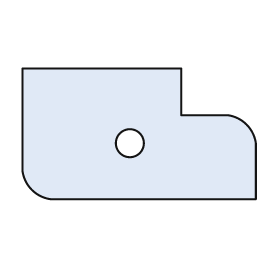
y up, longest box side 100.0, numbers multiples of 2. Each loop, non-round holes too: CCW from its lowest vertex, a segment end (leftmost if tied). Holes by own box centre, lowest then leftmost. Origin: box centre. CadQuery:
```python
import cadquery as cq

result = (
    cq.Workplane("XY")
    .moveTo(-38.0, -28.0)
    .lineTo(50.0, -28.0)
    .lineTo(50.0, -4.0)
    .threePointArc((46.0, 4.0), (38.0, 8.0))
    .lineTo(18.0, 8.0)
    .lineTo(18.0, 28.0)
    .lineTo(-50.0, 28.0)
    .lineTo(-50.0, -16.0)
    .threePointArc((-46.0, -24.0), (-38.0, -28.0))
    .close()
    .moveTo(-4.0, -4.0)
    .circle(6.0)
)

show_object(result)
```